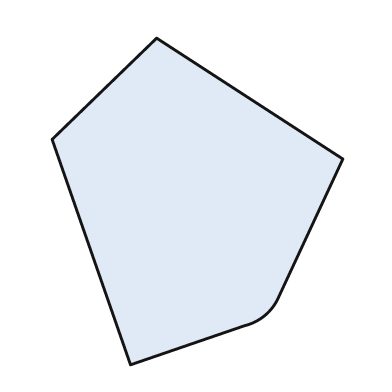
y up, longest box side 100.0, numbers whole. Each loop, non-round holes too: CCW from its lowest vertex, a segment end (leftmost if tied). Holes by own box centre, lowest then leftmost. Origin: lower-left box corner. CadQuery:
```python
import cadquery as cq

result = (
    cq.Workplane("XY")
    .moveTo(24.0, 0.0)
    .lineTo(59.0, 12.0)
    .threePointArc((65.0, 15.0), (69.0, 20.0))
    .lineTo(89.0, 63.0)
    .lineTo(32.0, 100.0)
    .lineTo(0.0, 69.0)
    .close()
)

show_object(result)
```